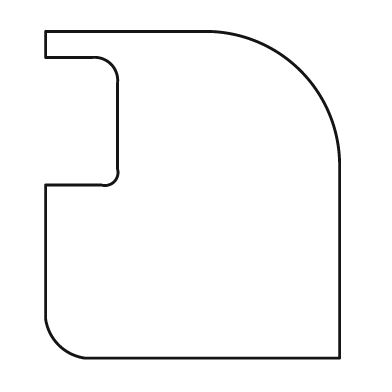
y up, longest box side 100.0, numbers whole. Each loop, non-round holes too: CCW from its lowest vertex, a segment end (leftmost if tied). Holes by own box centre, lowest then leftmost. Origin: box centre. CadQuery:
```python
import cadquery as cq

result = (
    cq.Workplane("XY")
    .moveTo(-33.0, -50.0)
    .lineTo(45.0, -50.0)
    .lineTo(45.0, 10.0)
    .threePointArc((33.0, 38.0), (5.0, 50.0))
    .lineTo(-45.0, 50.0)
    .lineTo(-45.0, 42.0)
    .lineTo(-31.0, 42.0)
    .threePointArc((-25.0, 40.0), (-23.0, 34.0))
    .lineTo(-23.0, 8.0)
    .threePointArc((-24.0, 4.0), (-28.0, 3.0))
    .lineTo(-45.0, 3.0)
    .lineTo(-45.0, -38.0)
    .threePointArc((-41.0, -46.0), (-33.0, -50.0))
    .close()
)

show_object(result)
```